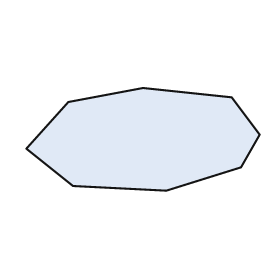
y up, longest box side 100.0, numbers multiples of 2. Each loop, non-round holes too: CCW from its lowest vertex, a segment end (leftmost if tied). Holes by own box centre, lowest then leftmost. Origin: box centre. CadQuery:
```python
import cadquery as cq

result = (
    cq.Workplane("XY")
    .moveTo(10.0, -22.0)
    .lineTo(42.0, -12.0)
    .lineTo(50.0, 2.0)
    .lineTo(38.0, 18.0)
    .lineTo(0.0, 22.0)
    .lineTo(-32.0, 16.0)
    .lineTo(-50.0, -4.0)
    .lineTo(-30.0, -20.0)
    .close()
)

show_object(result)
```